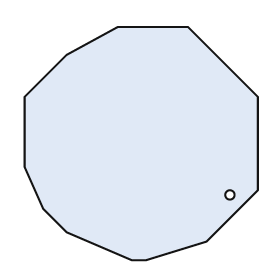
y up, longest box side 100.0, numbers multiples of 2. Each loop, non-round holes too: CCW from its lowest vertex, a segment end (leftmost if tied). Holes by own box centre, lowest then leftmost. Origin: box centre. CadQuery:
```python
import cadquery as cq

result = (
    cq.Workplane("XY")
    .moveTo(-4.0, -50.0)
    .lineTo(2.0, -50.0)
    .lineTo(28.0, -42.0)
    .lineTo(50.0, -20.0)
    .lineTo(50.0, 20.0)
    .lineTo(20.0, 50.0)
    .lineTo(-10.0, 50.0)
    .lineTo(-32.0, 38.0)
    .lineTo(-50.0, 20.0)
    .lineTo(-50.0, -10.0)
    .lineTo(-42.0, -28.0)
    .lineTo(-32.0, -38.0)
    .close()
    .moveTo(38.0, -22.0)
    .circle(2.0)
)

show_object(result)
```